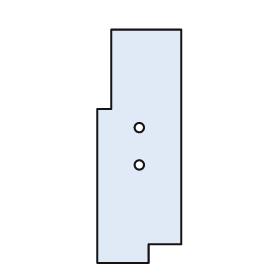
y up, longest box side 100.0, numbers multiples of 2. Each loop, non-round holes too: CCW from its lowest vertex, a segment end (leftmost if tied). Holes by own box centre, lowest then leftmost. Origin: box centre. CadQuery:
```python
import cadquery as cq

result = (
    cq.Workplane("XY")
    .moveTo(-18.0, -50.0)
    .lineTo(4.0, -50.0)
    .lineTo(4.0, -42.0)
    .lineTo(18.0, -42.0)
    .lineTo(18.0, 50.0)
    .lineTo(-12.0, 50.0)
    .lineTo(-12.0, 16.0)
    .lineTo(-18.0, 16.0)
    .close()
    .moveTo(0.0, -8.0)
    .circle(2.0)
    .moveTo(0.0, 8.0)
    .circle(2.0)
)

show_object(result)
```